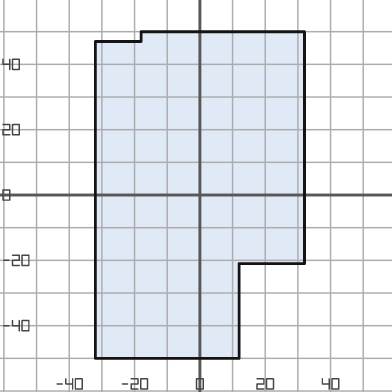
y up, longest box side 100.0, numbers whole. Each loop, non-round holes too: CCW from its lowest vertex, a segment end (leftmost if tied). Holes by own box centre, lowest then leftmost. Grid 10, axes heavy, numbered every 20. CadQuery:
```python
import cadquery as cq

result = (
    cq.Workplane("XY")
    .moveTo(-32.0, -50.0)
    .lineTo(12.0, -50.0)
    .lineTo(12.0, -21.0)
    .lineTo(32.0, -21.0)
    .lineTo(32.0, 50.0)
    .lineTo(-18.0, 50.0)
    .lineTo(-18.0, 47.0)
    .lineTo(-32.0, 47.0)
    .close()
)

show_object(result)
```